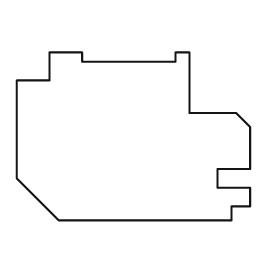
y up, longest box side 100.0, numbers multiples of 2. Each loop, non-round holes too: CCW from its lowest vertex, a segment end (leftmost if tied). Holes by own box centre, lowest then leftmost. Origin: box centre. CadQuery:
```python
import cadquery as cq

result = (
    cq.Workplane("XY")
    .moveTo(-32.0, -36.0)
    .lineTo(42.0, -36.0)
    .lineTo(42.0, -30.0)
    .lineTo(50.0, -30.0)
    .lineTo(50.0, -22.0)
    .lineTo(36.0, -22.0)
    .lineTo(36.0, -14.0)
    .lineTo(50.0, -14.0)
    .lineTo(50.0, 4.0)
    .lineTo(44.0, 10.0)
    .lineTo(24.0, 10.0)
    .lineTo(24.0, 36.0)
    .lineTo(18.0, 36.0)
    .lineTo(18.0, 32.0)
    .lineTo(-22.0, 32.0)
    .lineTo(-22.0, 36.0)
    .lineTo(-36.0, 36.0)
    .lineTo(-36.0, 24.0)
    .lineTo(-50.0, 24.0)
    .lineTo(-50.0, -18.0)
    .close()
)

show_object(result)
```